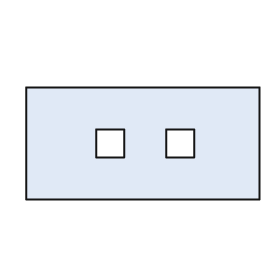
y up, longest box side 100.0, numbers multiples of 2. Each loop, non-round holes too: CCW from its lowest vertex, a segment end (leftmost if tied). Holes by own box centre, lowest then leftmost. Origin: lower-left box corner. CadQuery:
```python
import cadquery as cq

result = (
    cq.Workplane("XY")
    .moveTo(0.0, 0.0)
    .lineTo(100.0, 0.0)
    .lineTo(100.0, 48.0)
    .lineTo(0.0, 48.0)
    .close()
    .moveTo(30.0, 18.0)
    .lineTo(42.0, 18.0)
    .lineTo(42.0, 30.0)
    .lineTo(30.0, 30.0)
    .close()
    .moveTo(60.0, 18.0)
    .lineTo(72.0, 18.0)
    .lineTo(72.0, 30.0)
    .lineTo(60.0, 30.0)
    .close()
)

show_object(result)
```